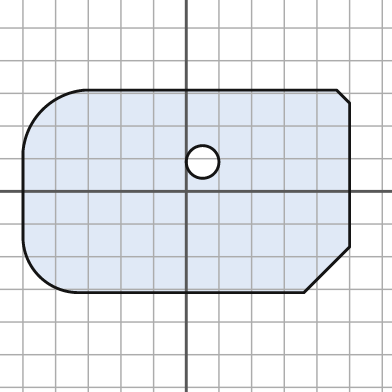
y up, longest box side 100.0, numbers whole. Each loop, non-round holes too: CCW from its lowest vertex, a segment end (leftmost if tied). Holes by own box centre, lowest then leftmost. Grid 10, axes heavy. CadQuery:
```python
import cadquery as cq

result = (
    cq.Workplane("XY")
    .moveTo(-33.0, -31.0)
    .lineTo(36.0, -31.0)
    .lineTo(50.0, -17.0)
    .lineTo(50.0, 27.0)
    .lineTo(46.0, 31.0)
    .lineTo(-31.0, 31.0)
    .threePointArc((-44.0, 25.0), (-50.0, 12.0))
    .lineTo(-50.0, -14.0)
    .threePointArc((-45.0, -26.0), (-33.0, -31.0))
    .close()
    .moveTo(5.0, 9.0)
    .circle(5.0)
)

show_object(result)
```